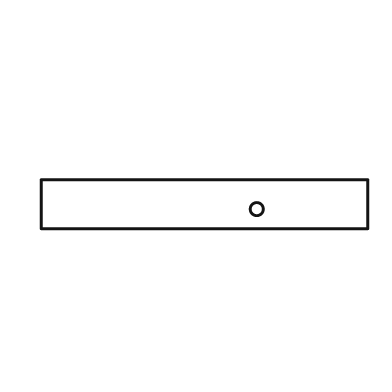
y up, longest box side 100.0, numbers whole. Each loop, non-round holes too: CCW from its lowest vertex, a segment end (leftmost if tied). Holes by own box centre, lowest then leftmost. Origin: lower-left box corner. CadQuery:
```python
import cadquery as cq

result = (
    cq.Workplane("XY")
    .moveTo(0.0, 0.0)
    .lineTo(100.0, 0.0)
    .lineTo(100.0, 15.0)
    .lineTo(0.0, 15.0)
    .close()
    .moveTo(66.0, 6.0)
    .circle(2.0)
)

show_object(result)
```